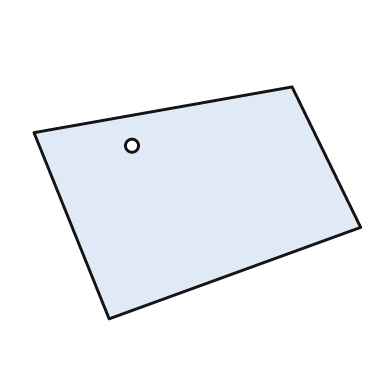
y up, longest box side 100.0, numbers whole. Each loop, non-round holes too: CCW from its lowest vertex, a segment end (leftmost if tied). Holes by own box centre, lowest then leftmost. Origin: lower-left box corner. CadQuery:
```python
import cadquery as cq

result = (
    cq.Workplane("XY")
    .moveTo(23.0, 0.0)
    .lineTo(100.0, 28.0)
    .lineTo(79.0, 71.0)
    .lineTo(0.0, 57.0)
    .close()
    .moveTo(30.0, 53.0)
    .circle(2.0)
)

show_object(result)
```